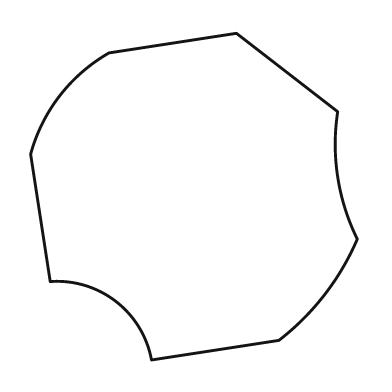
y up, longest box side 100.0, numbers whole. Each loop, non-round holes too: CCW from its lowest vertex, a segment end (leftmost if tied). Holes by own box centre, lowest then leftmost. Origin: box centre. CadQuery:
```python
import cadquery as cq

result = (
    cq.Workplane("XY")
    .moveTo(-13.0, -50.0)
    .lineTo(26.0, -44.0)
    .threePointArc((40.0, -30.0), (50.0, -13.0))
    .threePointArc((44.0, 6.0), (44.0, 26.0))
    .lineTo(13.0, 50.0)
    .lineTo(-26.0, 44.0)
    .threePointArc((-41.0, 31.0), (-50.0, 13.0))
    .lineTo(-44.0, -26.0)
    .threePointArc((-24.0, -32.0), (-13.0, -50.0))
    .close()
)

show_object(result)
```